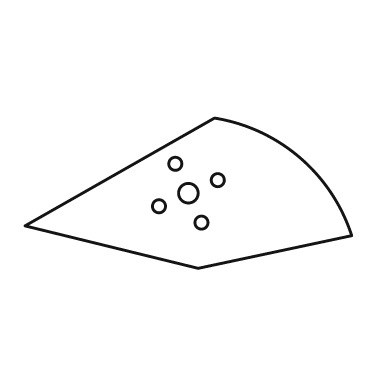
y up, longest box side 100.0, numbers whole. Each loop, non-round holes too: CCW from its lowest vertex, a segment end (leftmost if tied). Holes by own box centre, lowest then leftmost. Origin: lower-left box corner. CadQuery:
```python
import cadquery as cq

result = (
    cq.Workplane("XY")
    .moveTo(53.0, 0.0)
    .lineTo(100.0, 10.0)
    .threePointArc((84.0, 34.0), (58.0, 46.0))
    .lineTo(0.0, 13.0)
    .close()
    .moveTo(54.0, 14.0)
    .circle(2.0)
    .moveTo(41.0, 19.0)
    .circle(2.0)
    .moveTo(50.0, 23.0)
    .circle(3.0)
    .moveTo(59.0, 27.0)
    .circle(2.0)
    .moveTo(46.0, 32.0)
    .circle(2.0)
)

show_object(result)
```